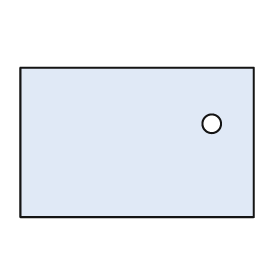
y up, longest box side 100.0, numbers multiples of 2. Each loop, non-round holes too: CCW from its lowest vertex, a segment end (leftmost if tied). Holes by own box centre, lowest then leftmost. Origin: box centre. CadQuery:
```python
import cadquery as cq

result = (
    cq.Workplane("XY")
    .moveTo(-50.0, -32.0)
    .lineTo(50.0, -32.0)
    .lineTo(50.0, 32.0)
    .lineTo(-50.0, 32.0)
    .close()
    .moveTo(32.0, 8.0)
    .circle(4.0)
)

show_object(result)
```